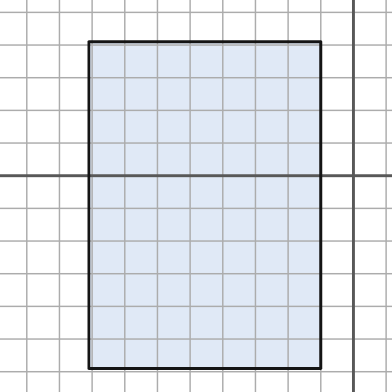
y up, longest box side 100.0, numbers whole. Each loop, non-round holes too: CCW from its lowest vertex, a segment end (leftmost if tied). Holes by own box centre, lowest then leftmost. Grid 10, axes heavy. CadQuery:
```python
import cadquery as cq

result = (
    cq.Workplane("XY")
    .moveTo(-81.0, -59.0)
    .lineTo(-10.0, -59.0)
    .lineTo(-10.0, 41.0)
    .lineTo(-81.0, 41.0)
    .close()
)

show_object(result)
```